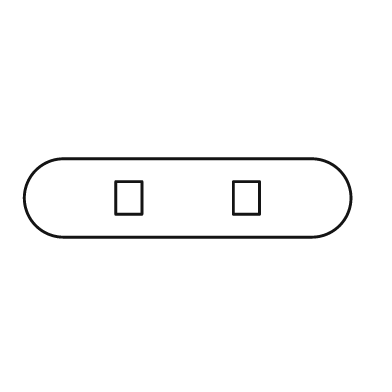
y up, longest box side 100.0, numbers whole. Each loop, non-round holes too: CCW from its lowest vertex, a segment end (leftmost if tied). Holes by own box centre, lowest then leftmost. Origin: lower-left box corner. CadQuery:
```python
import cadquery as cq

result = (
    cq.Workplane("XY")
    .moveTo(12.0, 0.0)
    .lineTo(88.0, 0.0)
    .threePointArc((100.0, 12.0), (88.0, 24.0))
    .lineTo(12.0, 24.0)
    .threePointArc((0.0, 12.0), (12.0, 0.0))
    .close()
    .moveTo(28.0, 7.0)
    .lineTo(36.0, 7.0)
    .lineTo(36.0, 17.0)
    .lineTo(28.0, 17.0)
    .close()
    .moveTo(64.0, 7.0)
    .lineTo(72.0, 7.0)
    .lineTo(72.0, 17.0)
    .lineTo(64.0, 17.0)
    .close()
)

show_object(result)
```